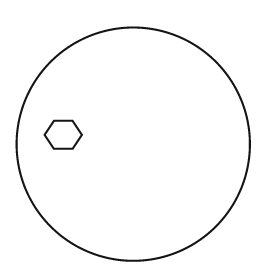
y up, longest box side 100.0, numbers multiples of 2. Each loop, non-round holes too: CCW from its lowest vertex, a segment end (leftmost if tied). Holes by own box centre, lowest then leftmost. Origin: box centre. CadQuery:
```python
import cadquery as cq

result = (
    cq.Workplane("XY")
    .moveTo(0.0, 0.0)
    .circle(50.0)
    .moveTo(-34.0, -2.0)
    .lineTo(-26.0, -2.0)
    .lineTo(-22.0, 4.0)
    .lineTo(-26.0, 10.0)
    .lineTo(-34.0, 10.0)
    .lineTo(-38.0, 4.0)
    .close()
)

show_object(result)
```